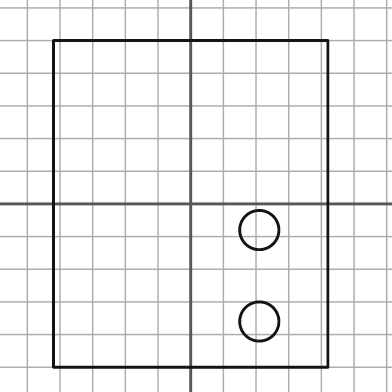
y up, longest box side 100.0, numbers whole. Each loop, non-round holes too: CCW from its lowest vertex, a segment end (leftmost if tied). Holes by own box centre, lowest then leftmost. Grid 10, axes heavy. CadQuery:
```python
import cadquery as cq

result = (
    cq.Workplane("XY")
    .moveTo(-42.0, -50.0)
    .lineTo(42.0, -50.0)
    .lineTo(42.0, 50.0)
    .lineTo(-42.0, 50.0)
    .close()
    .moveTo(21.0, -36.0)
    .circle(6.0)
    .moveTo(21.0, -8.0)
    .circle(6.0)
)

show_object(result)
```